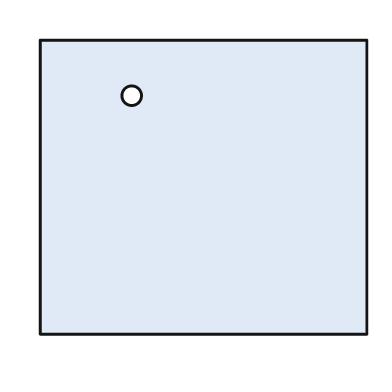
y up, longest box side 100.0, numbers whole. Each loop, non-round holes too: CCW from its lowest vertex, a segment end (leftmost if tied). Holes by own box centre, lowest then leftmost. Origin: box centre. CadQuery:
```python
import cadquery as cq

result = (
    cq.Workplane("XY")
    .moveTo(-50.0, -45.0)
    .lineTo(50.0, -45.0)
    .lineTo(50.0, 45.0)
    .lineTo(-50.0, 45.0)
    .close()
    .moveTo(-22.0, 28.0)
    .circle(3.0)
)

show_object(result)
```